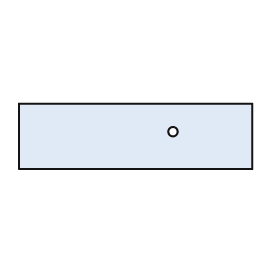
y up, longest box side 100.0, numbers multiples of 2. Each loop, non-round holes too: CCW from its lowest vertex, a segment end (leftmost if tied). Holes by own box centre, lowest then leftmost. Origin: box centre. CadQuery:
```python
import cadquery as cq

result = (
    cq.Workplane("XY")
    .moveTo(-50.0, -14.0)
    .lineTo(50.0, -14.0)
    .lineTo(50.0, 14.0)
    .lineTo(-50.0, 14.0)
    .close()
    .moveTo(16.0, 2.0)
    .circle(2.0)
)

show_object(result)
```